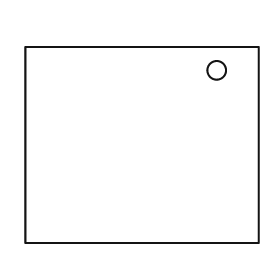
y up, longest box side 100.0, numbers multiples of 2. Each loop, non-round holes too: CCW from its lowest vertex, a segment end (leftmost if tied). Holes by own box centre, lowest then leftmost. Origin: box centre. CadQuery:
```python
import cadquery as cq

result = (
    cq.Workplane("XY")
    .moveTo(-50.0, -42.0)
    .lineTo(50.0, -42.0)
    .lineTo(50.0, 42.0)
    .lineTo(-50.0, 42.0)
    .close()
    .moveTo(32.0, 32.0)
    .circle(4.0)
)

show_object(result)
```